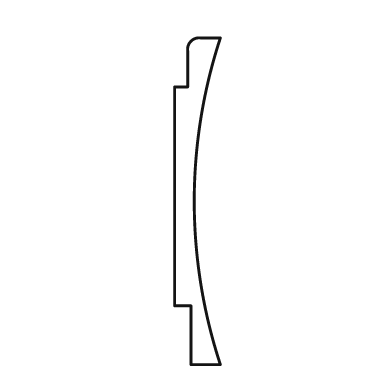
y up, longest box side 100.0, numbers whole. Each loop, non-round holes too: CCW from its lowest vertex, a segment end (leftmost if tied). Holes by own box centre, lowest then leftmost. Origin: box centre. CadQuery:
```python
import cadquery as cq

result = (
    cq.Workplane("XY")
    .moveTo(-2.0, -50.0)
    .lineTo(7.0, -50.0)
    .threePointArc((-1.0, 0.0), (7.0, 50.0))
    .lineTo(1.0, 50.0)
    .threePointArc((-2.0, 49.0), (-3.0, 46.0))
    .lineTo(-3.0, 35.0)
    .lineTo(-7.0, 35.0)
    .lineTo(-7.0, -32.0)
    .lineTo(-2.0, -32.0)
    .close()
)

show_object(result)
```